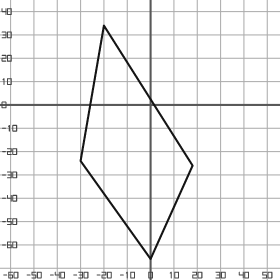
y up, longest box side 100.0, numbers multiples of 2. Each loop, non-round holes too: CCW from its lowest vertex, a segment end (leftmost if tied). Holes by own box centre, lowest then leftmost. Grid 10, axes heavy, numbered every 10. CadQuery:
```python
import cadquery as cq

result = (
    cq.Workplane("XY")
    .moveTo(0.0, -66.0)
    .lineTo(18.0, -26.0)
    .lineTo(-20.0, 34.0)
    .lineTo(-30.0, -24.0)
    .close()
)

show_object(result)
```